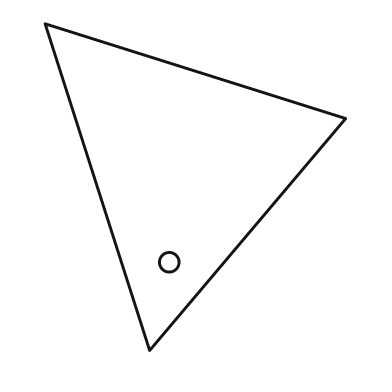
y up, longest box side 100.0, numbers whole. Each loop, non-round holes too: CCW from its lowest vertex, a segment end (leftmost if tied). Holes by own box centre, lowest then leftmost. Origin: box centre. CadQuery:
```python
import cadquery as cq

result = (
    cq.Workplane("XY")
    .moveTo(-14.0, -50.0)
    .lineTo(46.0, 21.0)
    .lineTo(-46.0, 50.0)
    .close()
    .moveTo(-8.0, -23.0)
    .circle(3.0)
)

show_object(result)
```